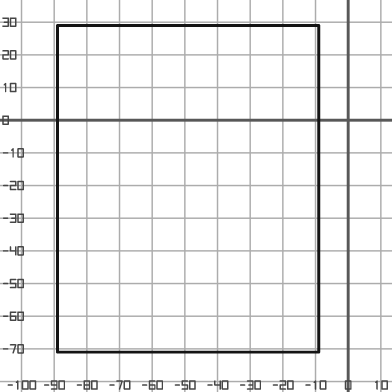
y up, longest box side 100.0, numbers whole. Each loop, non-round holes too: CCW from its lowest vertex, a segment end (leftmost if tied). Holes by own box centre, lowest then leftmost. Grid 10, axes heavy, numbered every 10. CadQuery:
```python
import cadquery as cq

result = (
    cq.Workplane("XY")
    .moveTo(-89.0, -71.0)
    .lineTo(-9.0, -71.0)
    .lineTo(-9.0, 29.0)
    .lineTo(-89.0, 29.0)
    .close()
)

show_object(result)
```